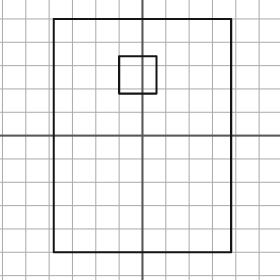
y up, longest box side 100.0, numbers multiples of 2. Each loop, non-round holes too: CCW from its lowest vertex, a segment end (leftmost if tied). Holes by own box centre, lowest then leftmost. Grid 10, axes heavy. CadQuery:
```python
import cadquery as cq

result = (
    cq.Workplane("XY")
    .moveTo(-38.0, -50.0)
    .lineTo(38.0, -50.0)
    .lineTo(38.0, 50.0)
    .lineTo(-38.0, 50.0)
    .close()
    .moveTo(-10.0, 18.0)
    .lineTo(6.0, 18.0)
    .lineTo(6.0, 34.0)
    .lineTo(-10.0, 34.0)
    .close()
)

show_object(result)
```